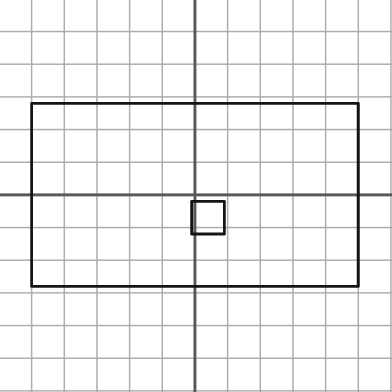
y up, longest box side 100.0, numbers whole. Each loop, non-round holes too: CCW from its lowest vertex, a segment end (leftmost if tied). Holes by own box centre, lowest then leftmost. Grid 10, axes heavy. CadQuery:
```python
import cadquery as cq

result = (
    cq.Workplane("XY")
    .moveTo(-50.0, -28.0)
    .lineTo(50.0, -28.0)
    .lineTo(50.0, 28.0)
    .lineTo(-50.0, 28.0)
    .close()
    .moveTo(-1.0, -12.0)
    .lineTo(9.0, -12.0)
    .lineTo(9.0, -2.0)
    .lineTo(-1.0, -2.0)
    .close()
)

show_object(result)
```